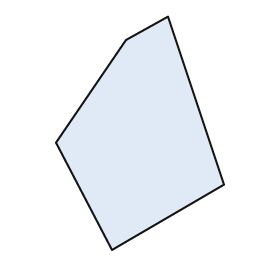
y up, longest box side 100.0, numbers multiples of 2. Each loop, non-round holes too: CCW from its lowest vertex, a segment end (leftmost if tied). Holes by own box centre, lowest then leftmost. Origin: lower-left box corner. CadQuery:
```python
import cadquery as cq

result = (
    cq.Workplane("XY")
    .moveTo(24.0, 0.0)
    .lineTo(72.0, 28.0)
    .lineTo(48.0, 100.0)
    .lineTo(30.0, 90.0)
    .lineTo(0.0, 46.0)
    .close()
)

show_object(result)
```